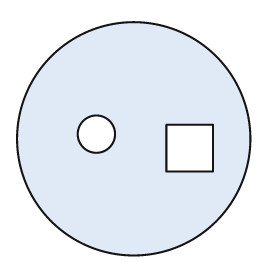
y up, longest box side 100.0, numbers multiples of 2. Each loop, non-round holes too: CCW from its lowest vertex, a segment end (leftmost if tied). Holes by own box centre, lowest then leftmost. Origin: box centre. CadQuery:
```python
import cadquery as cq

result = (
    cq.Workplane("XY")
    .moveTo(0.0, 0.0)
    .circle(50.0)
    .moveTo(14.0, -14.0)
    .lineTo(34.0, -14.0)
    .lineTo(34.0, 6.0)
    .lineTo(14.0, 6.0)
    .close()
    .moveTo(-16.0, 2.0)
    .circle(8.0)
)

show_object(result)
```